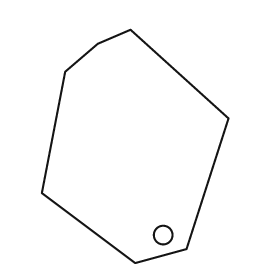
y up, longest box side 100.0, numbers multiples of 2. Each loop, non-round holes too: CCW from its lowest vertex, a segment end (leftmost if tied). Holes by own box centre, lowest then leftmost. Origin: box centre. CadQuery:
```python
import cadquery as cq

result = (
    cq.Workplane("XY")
    .moveTo(0.0, -50.0)
    .lineTo(22.0, -44.0)
    .lineTo(40.0, 12.0)
    .lineTo(-2.0, 50.0)
    .lineTo(-16.0, 44.0)
    .lineTo(-30.0, 32.0)
    .lineTo(-40.0, -20.0)
    .close()
    .moveTo(12.0, -38.0)
    .circle(4.0)
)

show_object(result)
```